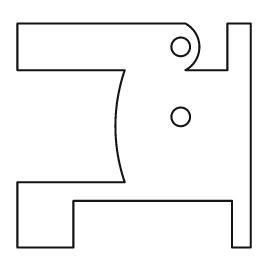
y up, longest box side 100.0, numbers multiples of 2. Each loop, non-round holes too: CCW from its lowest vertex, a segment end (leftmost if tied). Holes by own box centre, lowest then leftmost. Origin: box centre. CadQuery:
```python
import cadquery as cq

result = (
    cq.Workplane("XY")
    .moveTo(-50.0, -48.0)
    .lineTo(-26.0, -48.0)
    .lineTo(-26.0, -28.0)
    .lineTo(42.0, -28.0)
    .lineTo(42.0, -48.0)
    .lineTo(50.0, -48.0)
    .lineTo(50.0, 48.0)
    .lineTo(40.0, 48.0)
    .lineTo(40.0, 28.0)
    .lineTo(22.0, 28.0)
    .threePointArc((28.0, 38.0), (22.0, 48.0))
    .lineTo(-50.0, 48.0)
    .lineTo(-50.0, 28.0)
    .lineTo(-4.0, 28.0)
    .threePointArc((-8.0, 4.0), (-4.0, -20.0))
    .lineTo(-50.0, -20.0)
    .close()
    .moveTo(20.0, 8.0)
    .circle(4.0)
    .moveTo(20.0, 38.0)
    .circle(4.0)
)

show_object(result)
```